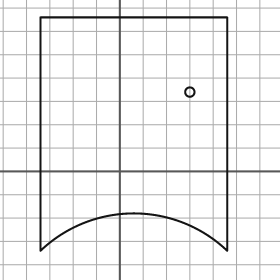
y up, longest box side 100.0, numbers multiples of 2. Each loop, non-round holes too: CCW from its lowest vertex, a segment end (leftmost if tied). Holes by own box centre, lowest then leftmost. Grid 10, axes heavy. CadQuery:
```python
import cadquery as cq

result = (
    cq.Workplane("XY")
    .moveTo(-34.0, -34.0)
    .threePointArc((6.0, -18.0), (46.0, -34.0))
    .lineTo(46.0, 66.0)
    .lineTo(-34.0, 66.0)
    .close()
    .moveTo(30.0, 34.0)
    .circle(2.0)
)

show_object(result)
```